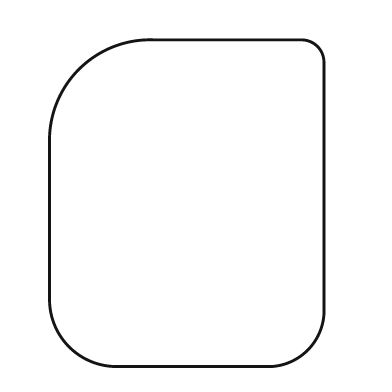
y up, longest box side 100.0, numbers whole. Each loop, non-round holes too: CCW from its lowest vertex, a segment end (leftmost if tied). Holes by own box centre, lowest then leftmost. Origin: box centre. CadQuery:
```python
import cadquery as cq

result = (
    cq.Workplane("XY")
    .moveTo(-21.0, -50.0)
    .lineTo(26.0, -50.0)
    .threePointArc((37.0, -45.0), (42.0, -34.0))
    .lineTo(42.0, 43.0)
    .threePointArc((40.0, 48.0), (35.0, 50.0))
    .lineTo(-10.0, 50.0)
    .threePointArc((-33.0, 41.0), (-42.0, 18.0))
    .lineTo(-42.0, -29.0)
    .threePointArc((-36.0, -44.0), (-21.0, -50.0))
    .close()
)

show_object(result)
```